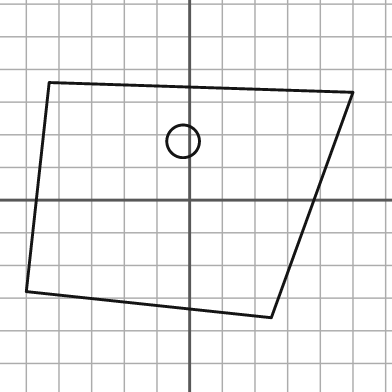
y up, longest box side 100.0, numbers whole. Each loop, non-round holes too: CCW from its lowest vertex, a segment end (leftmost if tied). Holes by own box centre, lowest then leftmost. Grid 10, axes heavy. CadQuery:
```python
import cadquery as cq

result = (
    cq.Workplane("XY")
    .moveTo(25.0, -36.0)
    .lineTo(50.0, 33.0)
    .lineTo(-43.0, 36.0)
    .lineTo(-50.0, -28.0)
    .close()
    .moveTo(-2.0, 18.0)
    .circle(5.0)
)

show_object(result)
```